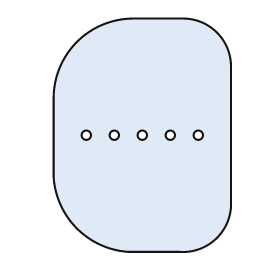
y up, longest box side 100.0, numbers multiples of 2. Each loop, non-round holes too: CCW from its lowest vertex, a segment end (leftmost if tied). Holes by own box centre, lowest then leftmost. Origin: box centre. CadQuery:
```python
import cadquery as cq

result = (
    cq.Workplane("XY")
    .moveTo(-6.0, -50.0)
    .lineTo(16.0, -50.0)
    .threePointArc((32.0, -44.0), (38.0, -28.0))
    .lineTo(38.0, 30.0)
    .threePointArc((32.0, 44.0), (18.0, 50.0))
    .lineTo(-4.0, 50.0)
    .threePointArc((-28.0, 40.0), (-38.0, 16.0))
    .lineTo(-38.0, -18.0)
    .threePointArc((-28.0, -40.0), (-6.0, -50.0))
    .close()
    .moveTo(-24.0, 0.0)
    .circle(2.0)
    .moveTo(-12.0, 0.0)
    .circle(2.0)
    .moveTo(0.0, 0.0)
    .circle(2.0)
    .moveTo(12.0, 0.0)
    .circle(2.0)
    .moveTo(24.0, 0.0)
    .circle(2.0)
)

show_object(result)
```